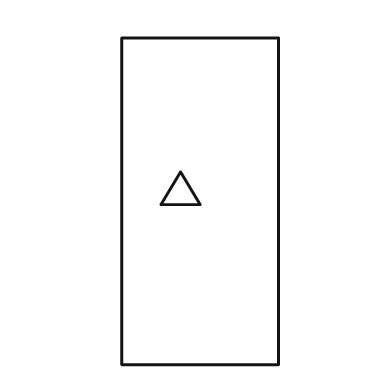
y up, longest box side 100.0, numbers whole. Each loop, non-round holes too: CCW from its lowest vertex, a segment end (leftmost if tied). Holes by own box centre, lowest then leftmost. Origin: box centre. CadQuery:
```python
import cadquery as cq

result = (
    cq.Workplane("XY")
    .moveTo(-24.0, -50.0)
    .lineTo(24.0, -50.0)
    .lineTo(24.0, 50.0)
    .lineTo(-24.0, 50.0)
    .close()
    .moveTo(-12.0, -1.0)
    .lineTo(0.0, -1.0)
    .lineTo(-6.0, 9.0)
    .close()
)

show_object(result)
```